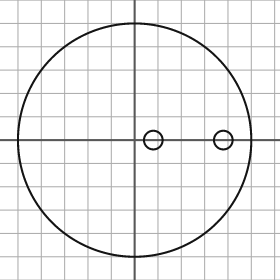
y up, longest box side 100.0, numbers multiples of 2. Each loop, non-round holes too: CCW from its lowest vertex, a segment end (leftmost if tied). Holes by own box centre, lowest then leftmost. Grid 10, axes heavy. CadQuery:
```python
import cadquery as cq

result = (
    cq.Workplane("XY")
    .moveTo(0.0, 0.0)
    .circle(50.0)
    .moveTo(8.0, 0.0)
    .circle(4.0)
    .moveTo(38.0, 0.0)
    .circle(4.0)
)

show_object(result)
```